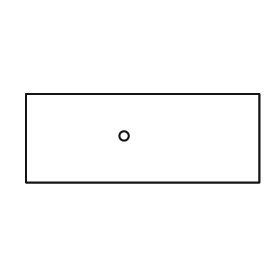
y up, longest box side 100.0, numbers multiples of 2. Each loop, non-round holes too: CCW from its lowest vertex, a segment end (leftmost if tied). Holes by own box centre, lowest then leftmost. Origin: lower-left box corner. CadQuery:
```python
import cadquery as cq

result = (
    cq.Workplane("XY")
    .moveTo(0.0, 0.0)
    .lineTo(100.0, 0.0)
    .lineTo(100.0, 38.0)
    .lineTo(0.0, 38.0)
    .close()
    .moveTo(42.0, 20.0)
    .circle(2.0)
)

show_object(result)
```